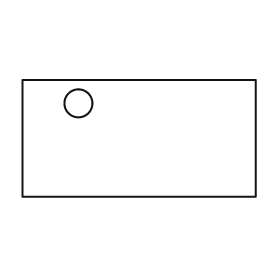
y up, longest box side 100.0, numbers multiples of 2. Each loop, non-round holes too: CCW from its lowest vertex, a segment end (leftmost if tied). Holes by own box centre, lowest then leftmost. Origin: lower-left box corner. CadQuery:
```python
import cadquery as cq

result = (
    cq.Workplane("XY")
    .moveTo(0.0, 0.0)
    .lineTo(100.0, 0.0)
    .lineTo(100.0, 50.0)
    .lineTo(0.0, 50.0)
    .close()
    .moveTo(24.0, 40.0)
    .circle(6.0)
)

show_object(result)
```